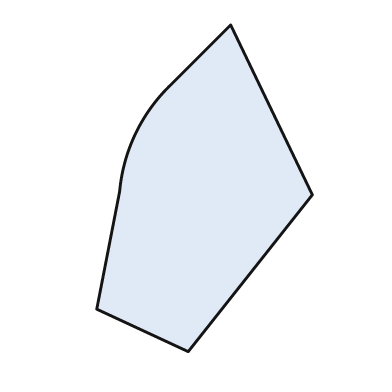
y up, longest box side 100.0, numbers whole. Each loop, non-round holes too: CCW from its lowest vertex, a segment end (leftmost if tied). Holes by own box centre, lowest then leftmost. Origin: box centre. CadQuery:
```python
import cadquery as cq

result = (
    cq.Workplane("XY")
    .moveTo(-5.0, -50.0)
    .lineTo(33.0, -2.0)
    .lineTo(8.0, 50.0)
    .lineTo(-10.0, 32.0)
    .threePointArc((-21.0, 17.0), (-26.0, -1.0))
    .lineTo(-33.0, -37.0)
    .close()
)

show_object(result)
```